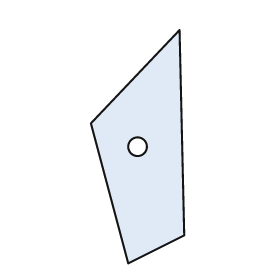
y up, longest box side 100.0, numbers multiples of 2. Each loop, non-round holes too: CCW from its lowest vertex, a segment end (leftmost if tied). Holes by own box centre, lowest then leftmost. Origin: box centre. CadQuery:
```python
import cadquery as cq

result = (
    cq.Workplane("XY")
    .moveTo(-4.0, -50.0)
    .lineTo(20.0, -38.0)
    .lineTo(18.0, 50.0)
    .lineTo(-20.0, 10.0)
    .close()
    .moveTo(0.0, 0.0)
    .circle(4.0)
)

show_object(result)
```